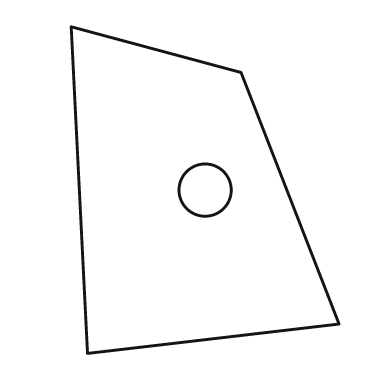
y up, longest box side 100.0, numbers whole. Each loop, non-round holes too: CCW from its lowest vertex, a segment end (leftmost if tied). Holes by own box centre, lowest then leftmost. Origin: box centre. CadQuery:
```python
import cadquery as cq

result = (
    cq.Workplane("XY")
    .moveTo(-36.0, -50.0)
    .lineTo(41.0, -41.0)
    .lineTo(11.0, 36.0)
    .lineTo(-41.0, 50.0)
    .close()
    .moveTo(0.0, 0.0)
    .circle(8.0)
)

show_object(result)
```